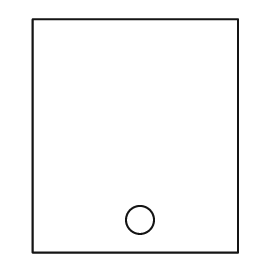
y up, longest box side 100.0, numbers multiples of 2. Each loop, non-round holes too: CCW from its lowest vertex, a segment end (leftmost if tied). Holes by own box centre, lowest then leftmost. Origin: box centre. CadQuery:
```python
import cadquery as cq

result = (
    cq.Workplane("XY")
    .moveTo(-44.0, -50.0)
    .lineTo(44.0, -50.0)
    .lineTo(44.0, 50.0)
    .lineTo(-44.0, 50.0)
    .close()
    .moveTo(2.0, -36.0)
    .circle(6.0)
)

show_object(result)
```